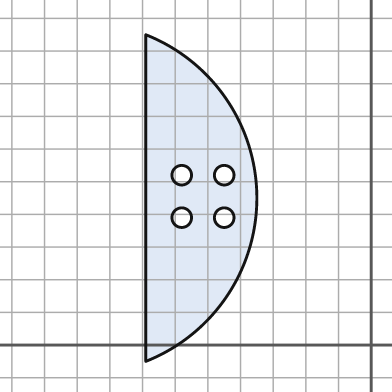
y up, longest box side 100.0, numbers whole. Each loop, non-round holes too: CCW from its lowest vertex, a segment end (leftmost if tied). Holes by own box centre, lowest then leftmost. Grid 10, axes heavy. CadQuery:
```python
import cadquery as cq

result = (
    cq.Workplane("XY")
    .moveTo(-69.0, -5.0)
    .threePointArc((-35.0, 45.0), (-69.0, 95.0))
    .close()
    .moveTo(-58.0, 39.0)
    .circle(3.0)
    .moveTo(-45.0, 39.0)
    .circle(3.0)
    .moveTo(-58.0, 52.0)
    .circle(3.0)
    .moveTo(-45.0, 52.0)
    .circle(3.0)
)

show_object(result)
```